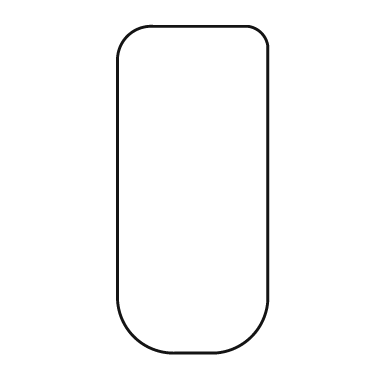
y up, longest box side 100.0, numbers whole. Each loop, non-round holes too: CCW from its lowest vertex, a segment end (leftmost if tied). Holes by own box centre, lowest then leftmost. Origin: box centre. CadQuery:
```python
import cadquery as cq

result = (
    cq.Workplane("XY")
    .moveTo(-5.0, -50.0)
    .lineTo(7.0, -50.0)
    .threePointArc((18.0, -45.0), (23.0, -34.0))
    .lineTo(23.0, 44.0)
    .threePointArc((21.0, 48.0), (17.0, 50.0))
    .lineTo(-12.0, 50.0)
    .threePointArc((-20.0, 47.0), (-23.0, 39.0))
    .lineTo(-23.0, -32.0)
    .threePointArc((-18.0, -45.0), (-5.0, -50.0))
    .close()
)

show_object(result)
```